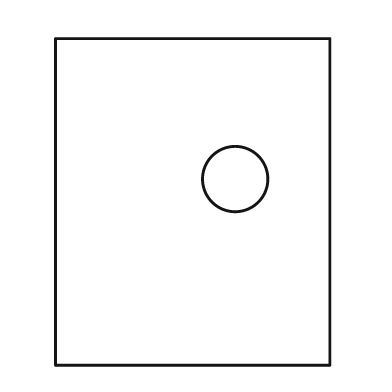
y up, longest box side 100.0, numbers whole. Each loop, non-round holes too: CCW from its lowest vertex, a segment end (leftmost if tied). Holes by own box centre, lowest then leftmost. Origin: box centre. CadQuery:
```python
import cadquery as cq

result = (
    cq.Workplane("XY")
    .moveTo(-42.0, -50.0)
    .lineTo(42.0, -50.0)
    .lineTo(42.0, 50.0)
    .lineTo(-42.0, 50.0)
    .close()
    .moveTo(13.0, 7.0)
    .circle(10.0)
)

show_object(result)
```